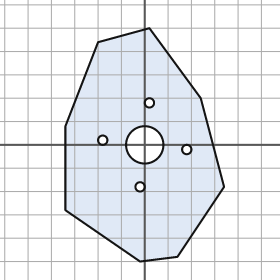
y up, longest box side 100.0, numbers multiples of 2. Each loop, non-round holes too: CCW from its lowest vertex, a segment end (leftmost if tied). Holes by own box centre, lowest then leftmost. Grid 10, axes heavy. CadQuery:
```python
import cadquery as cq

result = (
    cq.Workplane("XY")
    .moveTo(-2.0, -50.0)
    .lineTo(14.0, -48.0)
    .lineTo(34.0, -18.0)
    .lineTo(24.0, 20.0)
    .lineTo(2.0, 50.0)
    .lineTo(-20.0, 44.0)
    .lineTo(-34.0, 8.0)
    .lineTo(-34.0, -28.0)
    .close()
    .moveTo(-2.0, -18.0)
    .circle(2.0)
    .moveTo(18.0, -2.0)
    .circle(2.0)
    .moveTo(0.0, 0.0)
    .circle(8.0)
    .moveTo(-18.0, 2.0)
    .circle(2.0)
    .moveTo(2.0, 18.0)
    .circle(2.0)
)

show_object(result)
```